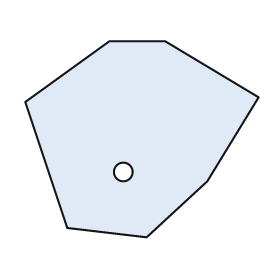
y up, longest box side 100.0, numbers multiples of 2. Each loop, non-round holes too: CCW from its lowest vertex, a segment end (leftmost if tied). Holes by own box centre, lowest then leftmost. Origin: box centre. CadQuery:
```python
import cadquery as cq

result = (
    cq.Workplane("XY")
    .moveTo(2.0, -42.0)
    .lineTo(28.0, -18.0)
    .lineTo(50.0, 18.0)
    .lineTo(10.0, 42.0)
    .lineTo(-14.0, 42.0)
    .lineTo(-50.0, 16.0)
    .lineTo(-32.0, -38.0)
    .close()
    .moveTo(-8.0, -14.0)
    .circle(4.0)
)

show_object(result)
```